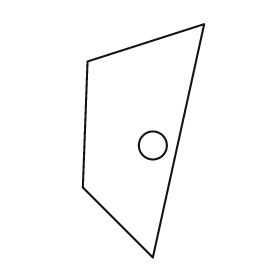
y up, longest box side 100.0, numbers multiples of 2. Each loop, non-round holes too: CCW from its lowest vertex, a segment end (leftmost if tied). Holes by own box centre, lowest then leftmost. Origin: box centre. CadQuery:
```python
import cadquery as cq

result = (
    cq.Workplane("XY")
    .moveTo(4.0, -50.0)
    .lineTo(26.0, 50.0)
    .lineTo(-24.0, 34.0)
    .lineTo(-26.0, -20.0)
    .close()
    .moveTo(4.0, -2.0)
    .circle(6.0)
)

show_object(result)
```